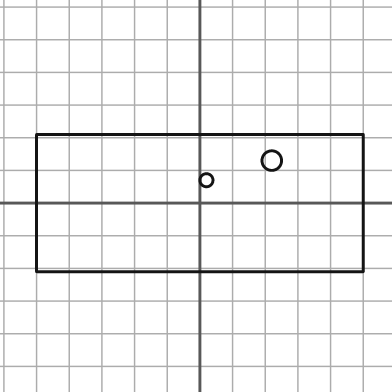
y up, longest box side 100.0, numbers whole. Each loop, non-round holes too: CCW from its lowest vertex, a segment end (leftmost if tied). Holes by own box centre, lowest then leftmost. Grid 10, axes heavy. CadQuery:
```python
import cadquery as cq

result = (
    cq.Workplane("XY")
    .moveTo(-50.0, -21.0)
    .lineTo(50.0, -21.0)
    .lineTo(50.0, 21.0)
    .lineTo(-50.0, 21.0)
    .close()
    .moveTo(2.0, 7.0)
    .circle(2.0)
    .moveTo(22.0, 13.0)
    .circle(3.0)
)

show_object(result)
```